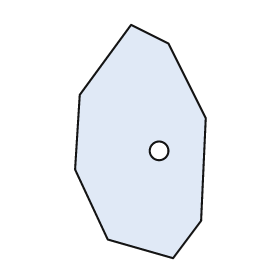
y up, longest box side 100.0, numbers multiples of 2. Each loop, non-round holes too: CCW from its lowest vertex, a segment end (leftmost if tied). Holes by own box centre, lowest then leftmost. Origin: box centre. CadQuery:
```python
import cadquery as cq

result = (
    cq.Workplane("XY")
    .moveTo(14.0, -50.0)
    .lineTo(26.0, -34.0)
    .lineTo(28.0, 10.0)
    .lineTo(12.0, 42.0)
    .lineTo(-4.0, 50.0)
    .lineTo(-26.0, 20.0)
    .lineTo(-28.0, -12.0)
    .lineTo(-14.0, -42.0)
    .close()
    .moveTo(8.0, -4.0)
    .circle(4.0)
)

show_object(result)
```